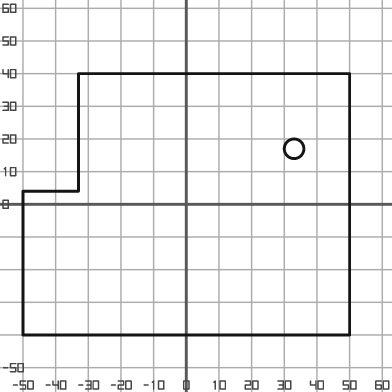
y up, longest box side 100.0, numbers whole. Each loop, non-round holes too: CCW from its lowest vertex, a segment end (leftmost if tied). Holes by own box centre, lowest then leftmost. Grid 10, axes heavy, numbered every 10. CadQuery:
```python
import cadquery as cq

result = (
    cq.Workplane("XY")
    .moveTo(-50.0, -40.0)
    .lineTo(50.0, -40.0)
    .lineTo(50.0, 40.0)
    .lineTo(-33.0, 40.0)
    .lineTo(-33.0, 4.0)
    .lineTo(-50.0, 4.0)
    .close()
    .moveTo(33.0, 17.0)
    .circle(3.0)
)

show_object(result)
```